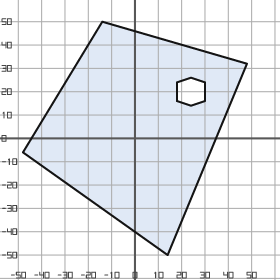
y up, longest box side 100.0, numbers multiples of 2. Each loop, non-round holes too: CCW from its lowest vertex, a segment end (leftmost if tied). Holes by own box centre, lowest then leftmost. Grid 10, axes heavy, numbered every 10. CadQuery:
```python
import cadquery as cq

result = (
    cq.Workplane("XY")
    .moveTo(14.0, -50.0)
    .lineTo(48.0, 32.0)
    .lineTo(-14.0, 50.0)
    .lineTo(-48.0, -6.0)
    .close()
    .moveTo(24.0, 14.0)
    .lineTo(30.0, 16.0)
    .lineTo(30.0, 24.0)
    .lineTo(24.0, 26.0)
    .lineTo(18.0, 24.0)
    .lineTo(18.0, 16.0)
    .close()
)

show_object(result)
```